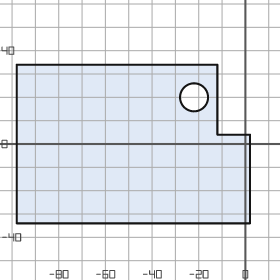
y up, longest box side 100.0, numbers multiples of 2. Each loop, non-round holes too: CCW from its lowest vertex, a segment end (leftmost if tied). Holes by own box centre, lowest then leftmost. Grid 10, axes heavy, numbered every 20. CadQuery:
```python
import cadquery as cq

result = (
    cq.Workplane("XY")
    .moveTo(-98.0, -34.0)
    .lineTo(2.0, -34.0)
    .lineTo(2.0, 4.0)
    .lineTo(-12.0, 4.0)
    .lineTo(-12.0, 34.0)
    .lineTo(-98.0, 34.0)
    .close()
    .moveTo(-22.0, 20.0)
    .circle(6.0)
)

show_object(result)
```